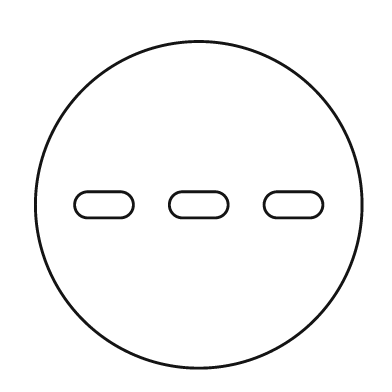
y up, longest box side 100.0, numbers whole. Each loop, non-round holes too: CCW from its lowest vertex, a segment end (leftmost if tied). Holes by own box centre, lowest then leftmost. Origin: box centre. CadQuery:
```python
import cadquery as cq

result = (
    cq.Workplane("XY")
    .moveTo(0.0, 0.0)
    .circle(50.0)
    .moveTo(-34.0, -4.0)
    .lineTo(-24.0, -4.0)
    .threePointArc((-20.0, 0.0), (-24.0, 4.0))
    .lineTo(-34.0, 4.0)
    .threePointArc((-38.0, 0.0), (-34.0, -4.0))
    .close()
    .moveTo(-5.0, -4.0)
    .lineTo(5.0, -4.0)
    .threePointArc((9.0, 0.0), (5.0, 4.0))
    .lineTo(-5.0, 4.0)
    .threePointArc((-9.0, 0.0), (-5.0, -4.0))
    .close()
    .moveTo(24.0, -4.0)
    .lineTo(34.0, -4.0)
    .threePointArc((38.0, 0.0), (34.0, 4.0))
    .lineTo(24.0, 4.0)
    .threePointArc((20.0, 0.0), (24.0, -4.0))
    .close()
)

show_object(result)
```